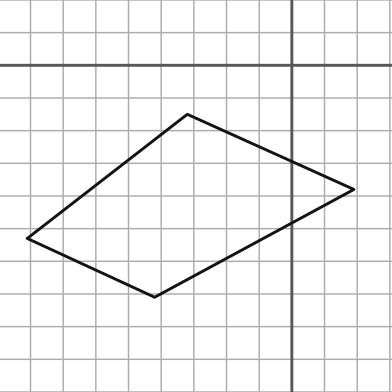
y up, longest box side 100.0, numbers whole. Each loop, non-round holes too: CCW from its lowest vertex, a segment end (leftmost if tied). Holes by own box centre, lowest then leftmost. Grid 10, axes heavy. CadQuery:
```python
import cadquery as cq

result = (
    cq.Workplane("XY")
    .moveTo(-42.0, -71.0)
    .lineTo(19.0, -38.0)
    .lineTo(-32.0, -15.0)
    .lineTo(-81.0, -53.0)
    .close()
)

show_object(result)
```